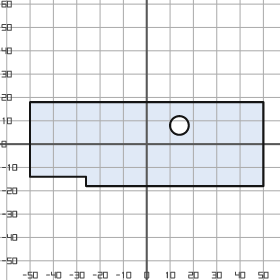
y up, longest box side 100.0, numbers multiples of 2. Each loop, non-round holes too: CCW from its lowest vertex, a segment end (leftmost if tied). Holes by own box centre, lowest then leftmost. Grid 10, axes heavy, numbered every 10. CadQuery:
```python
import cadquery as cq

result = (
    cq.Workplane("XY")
    .moveTo(-26.0, -18.0)
    .lineTo(50.0, -18.0)
    .lineTo(50.0, 18.0)
    .lineTo(-50.0, 18.0)
    .lineTo(-50.0, -14.0)
    .lineTo(-26.0, -14.0)
    .close()
    .moveTo(14.0, 8.0)
    .circle(4.0)
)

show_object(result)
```